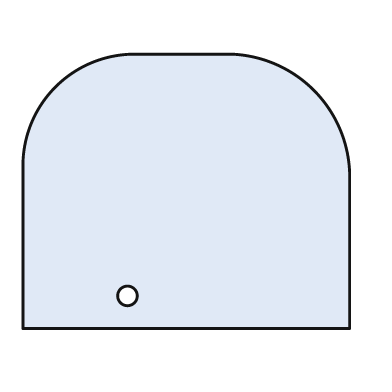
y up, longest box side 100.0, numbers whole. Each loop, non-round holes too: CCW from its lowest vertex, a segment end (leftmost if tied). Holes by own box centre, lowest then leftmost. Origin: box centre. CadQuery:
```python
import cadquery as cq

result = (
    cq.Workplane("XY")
    .moveTo(-50.0, -42.0)
    .lineTo(50.0, -42.0)
    .lineTo(50.0, 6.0)
    .threePointArc((39.0, 31.0), (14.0, 42.0))
    .lineTo(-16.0, 42.0)
    .threePointArc((-40.0, 32.0), (-50.0, 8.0))
    .close()
    .moveTo(-18.0, -32.0)
    .circle(3.0)
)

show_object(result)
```